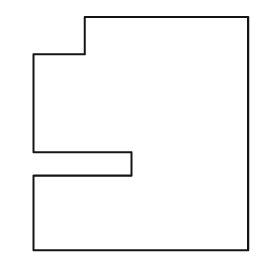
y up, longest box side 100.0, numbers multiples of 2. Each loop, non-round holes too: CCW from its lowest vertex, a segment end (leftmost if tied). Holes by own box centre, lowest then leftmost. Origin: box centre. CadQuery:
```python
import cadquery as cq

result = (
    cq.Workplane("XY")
    .moveTo(-46.0, -50.0)
    .lineTo(46.0, -50.0)
    .lineTo(46.0, 50.0)
    .lineTo(-24.0, 50.0)
    .lineTo(-24.0, 34.0)
    .lineTo(-46.0, 34.0)
    .lineTo(-46.0, -8.0)
    .lineTo(-4.0, -8.0)
    .lineTo(-4.0, -18.0)
    .lineTo(-46.0, -18.0)
    .close()
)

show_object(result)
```